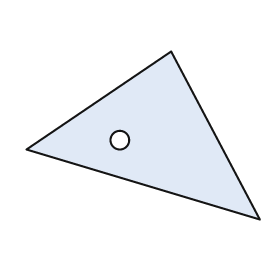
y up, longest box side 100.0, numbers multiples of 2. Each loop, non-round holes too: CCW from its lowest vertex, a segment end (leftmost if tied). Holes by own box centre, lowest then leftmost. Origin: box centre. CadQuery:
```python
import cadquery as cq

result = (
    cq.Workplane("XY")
    .moveTo(50.0, -36.0)
    .lineTo(12.0, 36.0)
    .lineTo(-50.0, -6.0)
    .close()
    .moveTo(-10.0, -2.0)
    .circle(4.0)
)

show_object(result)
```